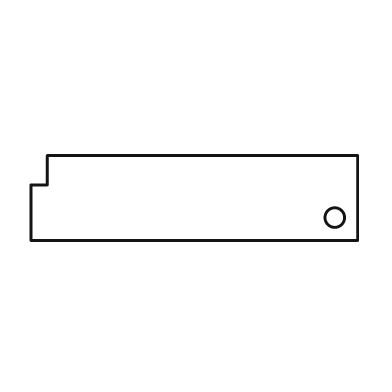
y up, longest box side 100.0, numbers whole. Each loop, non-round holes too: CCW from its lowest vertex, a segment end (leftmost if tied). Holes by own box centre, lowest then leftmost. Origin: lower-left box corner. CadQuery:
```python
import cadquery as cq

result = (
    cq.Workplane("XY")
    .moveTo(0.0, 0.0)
    .lineTo(100.0, 0.0)
    .lineTo(100.0, 26.0)
    .lineTo(5.0, 26.0)
    .lineTo(5.0, 17.0)
    .lineTo(0.0, 17.0)
    .close()
    .moveTo(93.0, 7.0)
    .circle(3.0)
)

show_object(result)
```